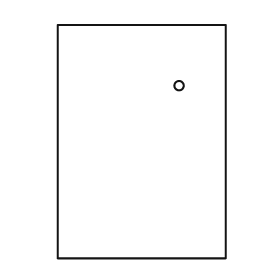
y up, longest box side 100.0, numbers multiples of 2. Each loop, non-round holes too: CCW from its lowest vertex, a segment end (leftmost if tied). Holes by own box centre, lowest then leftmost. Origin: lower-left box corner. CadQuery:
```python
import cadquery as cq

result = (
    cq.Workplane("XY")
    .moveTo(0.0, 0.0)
    .lineTo(72.0, 0.0)
    .lineTo(72.0, 100.0)
    .lineTo(0.0, 100.0)
    .close()
    .moveTo(52.0, 74.0)
    .circle(2.0)
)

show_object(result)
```